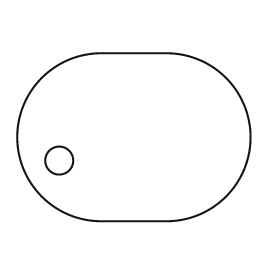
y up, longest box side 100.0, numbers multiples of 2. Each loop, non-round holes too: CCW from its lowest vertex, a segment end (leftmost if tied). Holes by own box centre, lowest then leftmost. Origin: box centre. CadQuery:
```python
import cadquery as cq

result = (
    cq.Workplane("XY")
    .moveTo(-14.0, -36.0)
    .lineTo(14.0, -36.0)
    .threePointArc((50.0, 0.0), (14.0, 36.0))
    .lineTo(-14.0, 36.0)
    .threePointArc((-50.0, 0.0), (-14.0, -36.0))
    .close()
    .moveTo(-32.0, -10.0)
    .circle(6.0)
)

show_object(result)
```